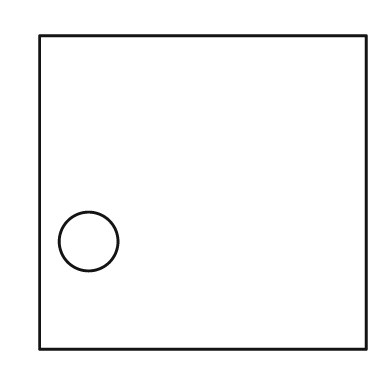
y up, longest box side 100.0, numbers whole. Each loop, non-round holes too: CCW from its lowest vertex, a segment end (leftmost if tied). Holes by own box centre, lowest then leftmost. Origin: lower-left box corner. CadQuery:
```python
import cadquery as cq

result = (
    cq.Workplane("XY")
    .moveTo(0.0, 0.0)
    .lineTo(100.0, 0.0)
    .lineTo(100.0, 96.0)
    .lineTo(0.0, 96.0)
    .close()
    .moveTo(15.0, 33.0)
    .circle(9.0)
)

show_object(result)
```